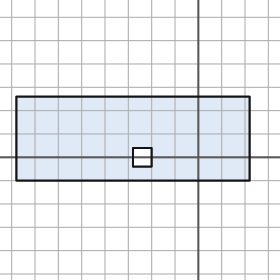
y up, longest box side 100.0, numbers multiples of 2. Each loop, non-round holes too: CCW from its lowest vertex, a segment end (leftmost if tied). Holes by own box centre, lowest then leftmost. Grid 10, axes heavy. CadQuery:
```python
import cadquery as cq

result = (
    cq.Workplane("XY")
    .moveTo(-78.0, -10.0)
    .lineTo(22.0, -10.0)
    .lineTo(22.0, 26.0)
    .lineTo(-78.0, 26.0)
    .close()
    .moveTo(-28.0, -4.0)
    .lineTo(-20.0, -4.0)
    .lineTo(-20.0, 4.0)
    .lineTo(-28.0, 4.0)
    .close()
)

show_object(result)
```